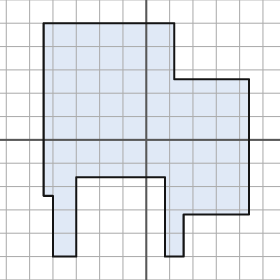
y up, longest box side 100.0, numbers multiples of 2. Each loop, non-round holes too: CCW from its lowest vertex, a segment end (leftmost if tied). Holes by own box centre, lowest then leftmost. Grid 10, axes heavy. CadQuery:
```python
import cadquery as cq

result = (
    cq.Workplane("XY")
    .moveTo(-40.0, -50.0)
    .lineTo(-30.0, -50.0)
    .lineTo(-30.0, -16.0)
    .lineTo(8.0, -16.0)
    .lineTo(8.0, -50.0)
    .lineTo(16.0, -50.0)
    .lineTo(16.0, -32.0)
    .lineTo(44.0, -32.0)
    .lineTo(44.0, 26.0)
    .lineTo(12.0, 26.0)
    .lineTo(12.0, 50.0)
    .lineTo(-44.0, 50.0)
    .lineTo(-44.0, -24.0)
    .lineTo(-40.0, -24.0)
    .close()
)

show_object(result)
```